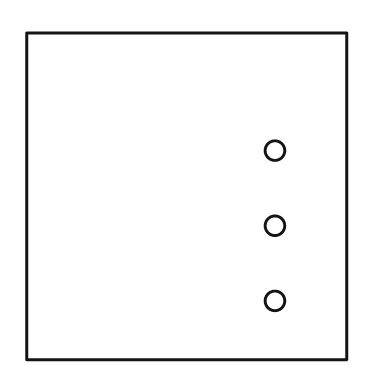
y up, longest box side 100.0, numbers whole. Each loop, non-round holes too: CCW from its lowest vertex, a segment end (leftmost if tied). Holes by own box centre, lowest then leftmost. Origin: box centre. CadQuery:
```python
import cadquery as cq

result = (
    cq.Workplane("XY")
    .moveTo(-49.0, -50.0)
    .lineTo(49.0, -50.0)
    .lineTo(49.0, 50.0)
    .lineTo(-49.0, 50.0)
    .close()
    .moveTo(27.0, -32.0)
    .circle(3.0)
    .moveTo(27.0, -9.0)
    .circle(3.0)
    .moveTo(27.0, 14.0)
    .circle(3.0)
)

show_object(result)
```